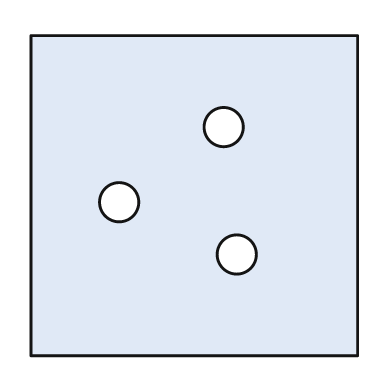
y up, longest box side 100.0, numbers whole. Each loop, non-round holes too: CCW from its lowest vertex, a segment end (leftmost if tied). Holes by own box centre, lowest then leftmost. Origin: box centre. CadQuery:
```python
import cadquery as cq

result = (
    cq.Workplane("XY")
    .moveTo(-50.0, -49.0)
    .lineTo(50.0, -49.0)
    .lineTo(50.0, 49.0)
    .lineTo(-50.0, 49.0)
    .close()
    .moveTo(13.0, -18.0)
    .circle(6.0)
    .moveTo(-23.0, -2.0)
    .circle(6.0)
    .moveTo(9.0, 21.0)
    .circle(6.0)
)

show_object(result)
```